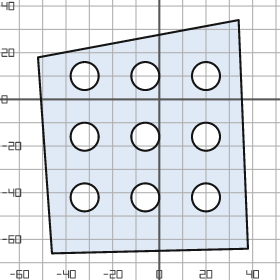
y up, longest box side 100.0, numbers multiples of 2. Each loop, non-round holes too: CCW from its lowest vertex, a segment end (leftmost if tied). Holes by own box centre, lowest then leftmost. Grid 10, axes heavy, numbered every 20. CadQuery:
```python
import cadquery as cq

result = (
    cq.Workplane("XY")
    .moveTo(-46.0, -66.0)
    .lineTo(38.0, -64.0)
    .lineTo(34.0, 34.0)
    .lineTo(-52.0, 18.0)
    .close()
    .moveTo(-32.0, -42.0)
    .circle(6.0)
    .moveTo(-6.0, -42.0)
    .circle(6.0)
    .moveTo(20.0, -42.0)
    .circle(6.0)
    .moveTo(-32.0, -16.0)
    .circle(6.0)
    .moveTo(-6.0, -16.0)
    .circle(6.0)
    .moveTo(20.0, -16.0)
    .circle(6.0)
    .moveTo(-32.0, 10.0)
    .circle(6.0)
    .moveTo(-6.0, 10.0)
    .circle(6.0)
    .moveTo(20.0, 10.0)
    .circle(6.0)
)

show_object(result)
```